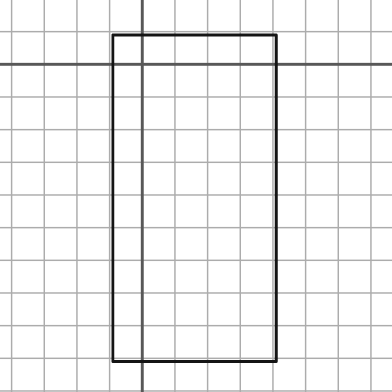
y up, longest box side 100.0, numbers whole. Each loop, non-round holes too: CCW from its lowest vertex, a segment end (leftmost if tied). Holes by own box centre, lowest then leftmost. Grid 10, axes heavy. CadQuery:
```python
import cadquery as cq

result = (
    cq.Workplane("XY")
    .moveTo(-9.0, -91.0)
    .lineTo(41.0, -91.0)
    .lineTo(41.0, 9.0)
    .lineTo(-9.0, 9.0)
    .close()
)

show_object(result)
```